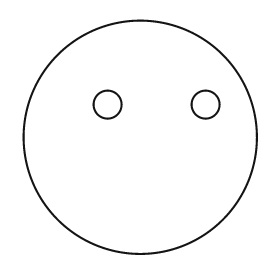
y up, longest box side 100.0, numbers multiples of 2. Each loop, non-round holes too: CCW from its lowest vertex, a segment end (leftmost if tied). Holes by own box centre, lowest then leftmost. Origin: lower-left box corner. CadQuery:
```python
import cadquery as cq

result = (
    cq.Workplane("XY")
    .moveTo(50.0, 50.0)
    .circle(50.0)
    .moveTo(36.0, 64.0)
    .circle(6.0)
    .moveTo(78.0, 64.0)
    .circle(6.0)
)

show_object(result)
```